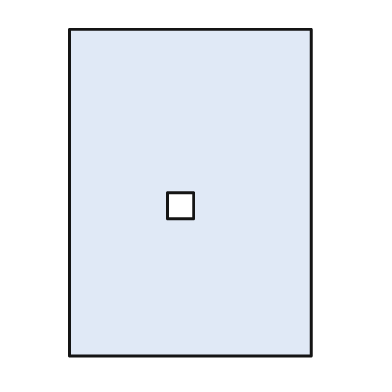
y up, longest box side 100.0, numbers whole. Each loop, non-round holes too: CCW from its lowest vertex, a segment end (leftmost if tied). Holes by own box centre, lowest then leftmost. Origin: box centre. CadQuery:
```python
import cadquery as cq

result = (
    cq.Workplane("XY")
    .moveTo(-37.0, -50.0)
    .lineTo(37.0, -50.0)
    .lineTo(37.0, 50.0)
    .lineTo(-37.0, 50.0)
    .close()
    .moveTo(-7.0, -8.0)
    .lineTo(1.0, -8.0)
    .lineTo(1.0, 0.0)
    .lineTo(-7.0, 0.0)
    .close()
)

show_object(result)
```